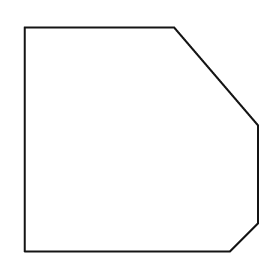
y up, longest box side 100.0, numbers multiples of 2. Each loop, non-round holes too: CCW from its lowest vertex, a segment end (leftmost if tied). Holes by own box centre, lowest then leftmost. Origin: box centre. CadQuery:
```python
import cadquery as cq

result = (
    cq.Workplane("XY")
    .moveTo(-50.0, -48.0)
    .lineTo(38.0, -48.0)
    .lineTo(50.0, -36.0)
    .lineTo(50.0, 6.0)
    .lineTo(14.0, 48.0)
    .lineTo(-50.0, 48.0)
    .close()
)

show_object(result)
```